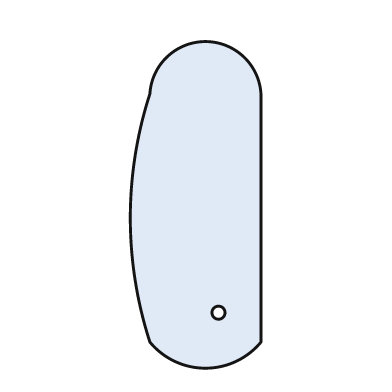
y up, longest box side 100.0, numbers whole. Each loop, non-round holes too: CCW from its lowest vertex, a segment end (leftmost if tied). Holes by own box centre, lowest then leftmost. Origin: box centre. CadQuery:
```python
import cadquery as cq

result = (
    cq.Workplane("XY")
    .moveTo(-14.0, -42.0)
    .threePointArc((3.0, -50.0), (20.0, -42.0))
    .lineTo(20.0, 34.0)
    .threePointArc((3.0, 50.0), (-14.0, 34.0))
    .threePointArc((-20.0, -4.0), (-14.0, -42.0))
    .close()
    .moveTo(7.0, -33.0)
    .circle(2.0)
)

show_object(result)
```